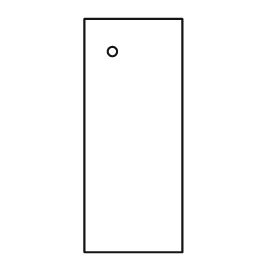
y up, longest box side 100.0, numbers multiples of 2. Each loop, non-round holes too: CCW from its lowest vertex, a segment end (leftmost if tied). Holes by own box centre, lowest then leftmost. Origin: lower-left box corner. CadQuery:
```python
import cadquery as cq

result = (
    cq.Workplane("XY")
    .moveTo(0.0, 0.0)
    .lineTo(42.0, 0.0)
    .lineTo(42.0, 100.0)
    .lineTo(0.0, 100.0)
    .close()
    .moveTo(12.0, 86.0)
    .circle(2.0)
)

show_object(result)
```